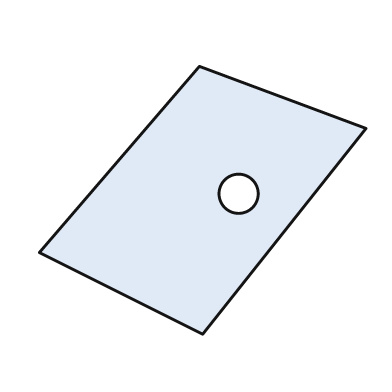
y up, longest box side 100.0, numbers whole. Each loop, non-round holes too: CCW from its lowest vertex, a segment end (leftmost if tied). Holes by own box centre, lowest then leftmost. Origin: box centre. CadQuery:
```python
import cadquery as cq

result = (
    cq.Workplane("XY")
    .moveTo(0.0, -41.0)
    .lineTo(50.0, 22.0)
    .lineTo(-1.0, 41.0)
    .lineTo(-50.0, -16.0)
    .close()
    .moveTo(11.0, 2.0)
    .circle(6.0)
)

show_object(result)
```